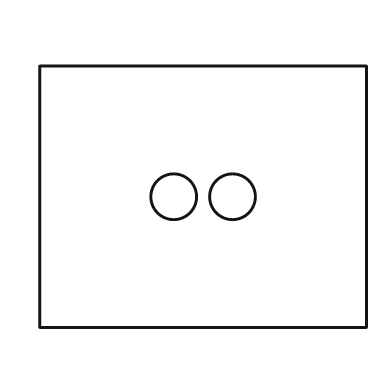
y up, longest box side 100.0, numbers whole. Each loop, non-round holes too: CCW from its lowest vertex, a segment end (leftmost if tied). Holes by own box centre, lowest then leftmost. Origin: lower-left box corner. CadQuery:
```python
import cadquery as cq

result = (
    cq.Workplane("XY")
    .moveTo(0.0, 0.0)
    .lineTo(100.0, 0.0)
    .lineTo(100.0, 80.0)
    .lineTo(0.0, 80.0)
    .close()
    .moveTo(41.0, 40.0)
    .circle(7.0)
    .moveTo(59.0, 40.0)
    .circle(7.0)
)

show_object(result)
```